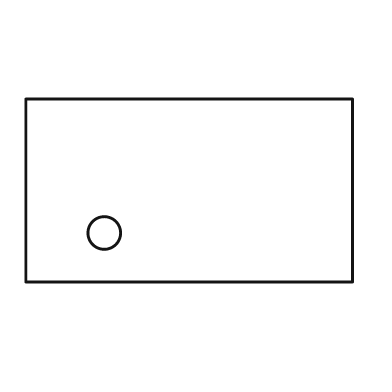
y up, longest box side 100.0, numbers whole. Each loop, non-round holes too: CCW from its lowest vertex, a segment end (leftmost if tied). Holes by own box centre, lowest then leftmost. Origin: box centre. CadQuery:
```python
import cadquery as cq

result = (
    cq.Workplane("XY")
    .moveTo(-50.0, -28.0)
    .lineTo(50.0, -28.0)
    .lineTo(50.0, 28.0)
    .lineTo(-50.0, 28.0)
    .close()
    .moveTo(-26.0, -13.0)
    .circle(5.0)
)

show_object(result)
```